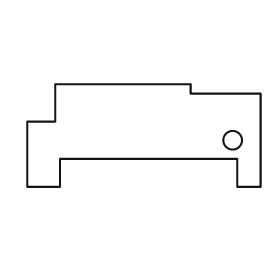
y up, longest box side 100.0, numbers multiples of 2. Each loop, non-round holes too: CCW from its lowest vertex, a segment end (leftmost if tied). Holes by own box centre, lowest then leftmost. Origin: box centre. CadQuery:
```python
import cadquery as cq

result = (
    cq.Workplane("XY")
    .moveTo(-50.0, -22.0)
    .lineTo(-36.0, -22.0)
    .lineTo(-36.0, -10.0)
    .lineTo(40.0, -10.0)
    .lineTo(40.0, -22.0)
    .lineTo(50.0, -22.0)
    .lineTo(50.0, 18.0)
    .lineTo(20.0, 18.0)
    .lineTo(20.0, 22.0)
    .lineTo(-38.0, 22.0)
    .lineTo(-38.0, 6.0)
    .lineTo(-50.0, 6.0)
    .close()
    .moveTo(38.0, -2.0)
    .circle(4.0)
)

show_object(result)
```